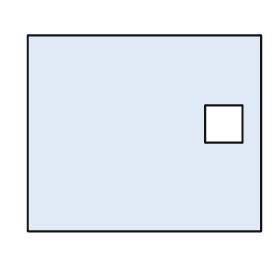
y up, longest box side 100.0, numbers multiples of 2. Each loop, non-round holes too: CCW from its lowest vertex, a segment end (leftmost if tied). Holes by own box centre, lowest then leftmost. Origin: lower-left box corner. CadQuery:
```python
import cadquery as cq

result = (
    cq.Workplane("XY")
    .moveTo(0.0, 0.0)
    .lineTo(100.0, 0.0)
    .lineTo(100.0, 84.0)
    .lineTo(0.0, 84.0)
    .close()
    .moveTo(76.0, 38.0)
    .lineTo(92.0, 38.0)
    .lineTo(92.0, 54.0)
    .lineTo(76.0, 54.0)
    .close()
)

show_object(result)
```